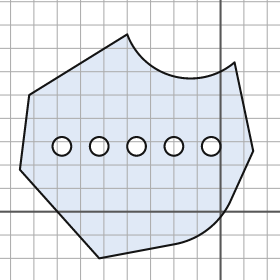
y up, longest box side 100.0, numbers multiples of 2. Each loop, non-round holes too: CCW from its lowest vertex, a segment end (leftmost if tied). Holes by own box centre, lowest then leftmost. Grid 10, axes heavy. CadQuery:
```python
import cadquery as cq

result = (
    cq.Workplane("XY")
    .moveTo(-52.0, -20.0)
    .lineTo(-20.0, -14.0)
    .threePointArc((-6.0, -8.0), (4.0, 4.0))
    .lineTo(14.0, 26.0)
    .lineTo(6.0, 64.0)
    .threePointArc((-20.0, 58.0), (-40.0, 76.0))
    .lineTo(-82.0, 50.0)
    .lineTo(-86.0, 18.0)
    .close()
    .moveTo(-68.0, 28.0)
    .circle(4.0)
    .moveTo(-52.0, 28.0)
    .circle(4.0)
    .moveTo(-36.0, 28.0)
    .circle(4.0)
    .moveTo(-20.0, 28.0)
    .circle(4.0)
    .moveTo(-4.0, 28.0)
    .circle(4.0)
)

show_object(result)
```